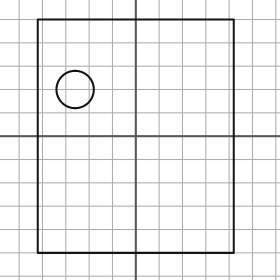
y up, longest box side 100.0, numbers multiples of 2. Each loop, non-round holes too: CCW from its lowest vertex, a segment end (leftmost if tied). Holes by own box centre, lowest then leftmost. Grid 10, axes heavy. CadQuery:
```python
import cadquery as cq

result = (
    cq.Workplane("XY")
    .moveTo(-42.0, -50.0)
    .lineTo(42.0, -50.0)
    .lineTo(42.0, 50.0)
    .lineTo(-42.0, 50.0)
    .close()
    .moveTo(-26.0, 20.0)
    .circle(8.0)
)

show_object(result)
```